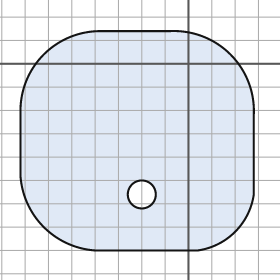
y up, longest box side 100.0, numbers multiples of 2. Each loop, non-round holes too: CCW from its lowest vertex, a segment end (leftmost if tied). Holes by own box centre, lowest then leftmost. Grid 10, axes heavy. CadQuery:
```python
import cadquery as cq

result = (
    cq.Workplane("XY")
    .moveTo(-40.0, -80.0)
    .lineTo(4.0, -80.0)
    .threePointArc((20.0, -72.0), (28.0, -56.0))
    .lineTo(28.0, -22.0)
    .threePointArc((18.0, 4.0), (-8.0, 14.0))
    .lineTo(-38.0, 14.0)
    .threePointArc((-62.0, 4.0), (-72.0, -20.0))
    .lineTo(-72.0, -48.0)
    .threePointArc((-62.0, -70.0), (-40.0, -80.0))
    .close()
    .moveTo(-20.0, -56.0)
    .circle(6.0)
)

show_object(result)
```